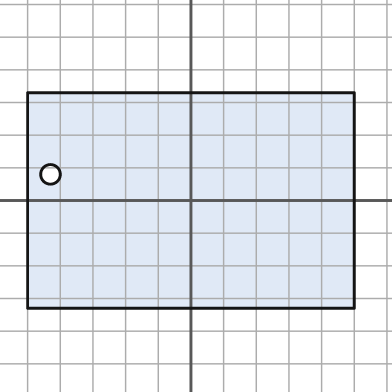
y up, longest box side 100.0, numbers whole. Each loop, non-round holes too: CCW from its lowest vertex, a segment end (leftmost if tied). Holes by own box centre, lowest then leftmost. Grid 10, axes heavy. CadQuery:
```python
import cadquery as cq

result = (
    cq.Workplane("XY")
    .moveTo(-50.0, -33.0)
    .lineTo(50.0, -33.0)
    .lineTo(50.0, 33.0)
    .lineTo(-50.0, 33.0)
    .close()
    .moveTo(-43.0, 8.0)
    .circle(3.0)
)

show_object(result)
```